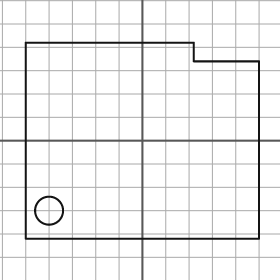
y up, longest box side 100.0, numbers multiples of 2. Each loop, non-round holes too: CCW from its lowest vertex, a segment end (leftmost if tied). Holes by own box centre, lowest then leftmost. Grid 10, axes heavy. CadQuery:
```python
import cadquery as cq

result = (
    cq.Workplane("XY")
    .moveTo(-50.0, -42.0)
    .lineTo(50.0, -42.0)
    .lineTo(50.0, 34.0)
    .lineTo(22.0, 34.0)
    .lineTo(22.0, 42.0)
    .lineTo(-50.0, 42.0)
    .close()
    .moveTo(-40.0, -30.0)
    .circle(6.0)
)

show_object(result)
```